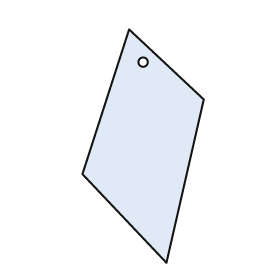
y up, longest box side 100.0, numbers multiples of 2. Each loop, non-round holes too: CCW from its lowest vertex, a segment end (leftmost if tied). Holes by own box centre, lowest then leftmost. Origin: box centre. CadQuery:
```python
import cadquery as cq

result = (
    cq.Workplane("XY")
    .moveTo(10.0, -50.0)
    .lineTo(26.0, 20.0)
    .lineTo(-6.0, 50.0)
    .lineTo(-26.0, -12.0)
    .close()
    .moveTo(0.0, 36.0)
    .circle(2.0)
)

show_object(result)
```